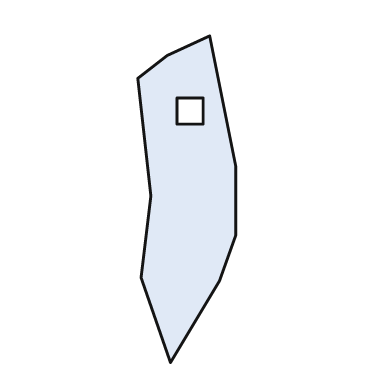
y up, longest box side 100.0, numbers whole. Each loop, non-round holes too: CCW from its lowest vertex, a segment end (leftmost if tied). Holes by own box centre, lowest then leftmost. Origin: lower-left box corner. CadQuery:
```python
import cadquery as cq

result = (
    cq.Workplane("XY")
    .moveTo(10.0, 0.0)
    .lineTo(25.0, 25.0)
    .lineTo(30.0, 39.0)
    .lineTo(30.0, 60.0)
    .lineTo(22.0, 100.0)
    .lineTo(9.0, 94.0)
    .lineTo(0.0, 87.0)
    .lineTo(4.0, 51.0)
    .lineTo(1.0, 26.0)
    .close()
    .moveTo(12.0, 73.0)
    .lineTo(20.0, 73.0)
    .lineTo(20.0, 81.0)
    .lineTo(12.0, 81.0)
    .close()
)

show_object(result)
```